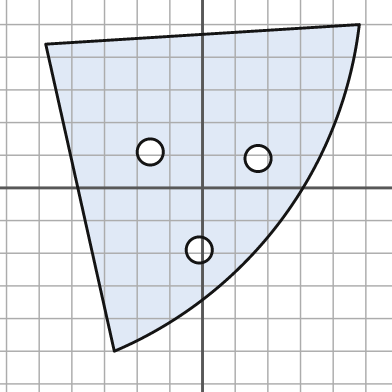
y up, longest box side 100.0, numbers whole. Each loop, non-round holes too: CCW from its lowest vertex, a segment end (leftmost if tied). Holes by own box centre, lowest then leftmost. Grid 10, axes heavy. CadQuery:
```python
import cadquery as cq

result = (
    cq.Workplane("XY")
    .moveTo(-27.0, -50.0)
    .threePointArc((24.0, -10.0), (48.0, 50.0))
    .lineTo(-48.0, 44.0)
    .close()
    .moveTo(-1.0, -19.0)
    .circle(4.0)
    .moveTo(17.0, 9.0)
    .circle(4.0)
    .moveTo(-16.0, 11.0)
    .circle(4.0)
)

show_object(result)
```